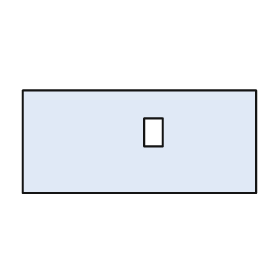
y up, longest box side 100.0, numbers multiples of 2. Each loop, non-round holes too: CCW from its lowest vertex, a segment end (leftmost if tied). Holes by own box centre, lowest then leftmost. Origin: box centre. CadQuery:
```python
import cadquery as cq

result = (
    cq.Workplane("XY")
    .moveTo(-50.0, -22.0)
    .lineTo(50.0, -22.0)
    .lineTo(50.0, 22.0)
    .lineTo(-50.0, 22.0)
    .close()
    .moveTo(2.0, -2.0)
    .lineTo(10.0, -2.0)
    .lineTo(10.0, 10.0)
    .lineTo(2.0, 10.0)
    .close()
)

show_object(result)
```